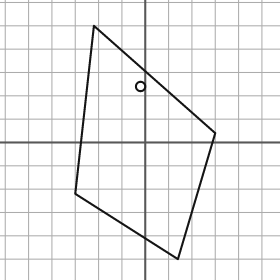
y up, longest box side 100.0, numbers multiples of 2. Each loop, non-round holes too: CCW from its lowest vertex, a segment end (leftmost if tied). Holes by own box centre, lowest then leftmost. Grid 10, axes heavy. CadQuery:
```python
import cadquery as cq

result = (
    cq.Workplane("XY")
    .moveTo(14.0, -50.0)
    .lineTo(30.0, 4.0)
    .lineTo(-22.0, 50.0)
    .lineTo(-30.0, -22.0)
    .close()
    .moveTo(-2.0, 24.0)
    .circle(2.0)
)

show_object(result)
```